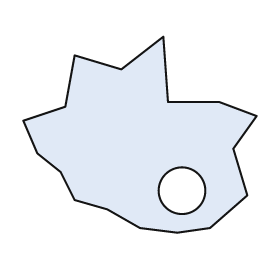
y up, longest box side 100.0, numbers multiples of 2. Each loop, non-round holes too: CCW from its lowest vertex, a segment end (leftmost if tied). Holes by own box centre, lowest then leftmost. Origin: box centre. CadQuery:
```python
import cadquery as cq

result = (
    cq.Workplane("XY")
    .moveTo(16.0, -42.0)
    .lineTo(30.0, -40.0)
    .lineTo(46.0, -26.0)
    .lineTo(40.0, -6.0)
    .lineTo(50.0, 8.0)
    .lineTo(34.0, 14.0)
    .lineTo(12.0, 14.0)
    .lineTo(10.0, 42.0)
    .lineTo(-8.0, 28.0)
    .lineTo(-28.0, 34.0)
    .lineTo(-32.0, 12.0)
    .lineTo(-50.0, 6.0)
    .lineTo(-44.0, -8.0)
    .lineTo(-34.0, -16.0)
    .lineTo(-28.0, -28.0)
    .lineTo(-14.0, -32.0)
    .lineTo(0.0, -40.0)
    .close()
    .moveTo(18.0, -24.0)
    .circle(10.0)
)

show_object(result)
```